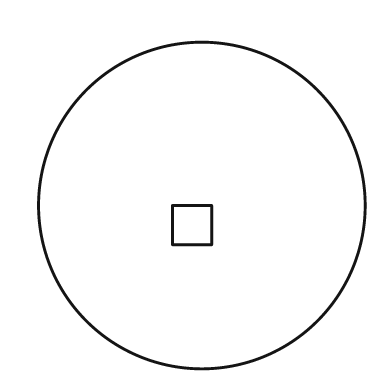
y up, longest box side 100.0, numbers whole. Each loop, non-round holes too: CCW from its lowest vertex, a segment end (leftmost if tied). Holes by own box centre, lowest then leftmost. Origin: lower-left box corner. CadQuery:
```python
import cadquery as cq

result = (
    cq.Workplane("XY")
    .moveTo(50.0, 50.0)
    .circle(50.0)
    .moveTo(41.0, 38.0)
    .lineTo(53.0, 38.0)
    .lineTo(53.0, 50.0)
    .lineTo(41.0, 50.0)
    .close()
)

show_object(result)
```